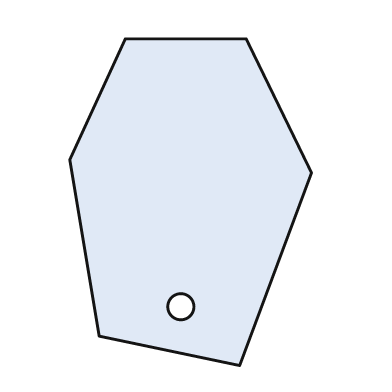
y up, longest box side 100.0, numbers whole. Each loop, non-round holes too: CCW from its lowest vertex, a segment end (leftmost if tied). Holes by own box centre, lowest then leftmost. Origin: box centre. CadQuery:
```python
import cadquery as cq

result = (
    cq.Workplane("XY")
    .moveTo(15.0, -50.0)
    .lineTo(37.0, 9.0)
    .lineTo(17.0, 50.0)
    .lineTo(-20.0, 50.0)
    .lineTo(-37.0, 13.0)
    .lineTo(-28.0, -41.0)
    .close()
    .moveTo(-3.0, -32.0)
    .circle(4.0)
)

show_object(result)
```